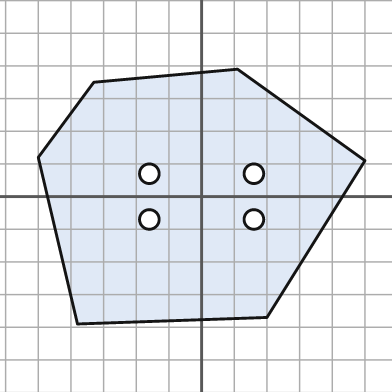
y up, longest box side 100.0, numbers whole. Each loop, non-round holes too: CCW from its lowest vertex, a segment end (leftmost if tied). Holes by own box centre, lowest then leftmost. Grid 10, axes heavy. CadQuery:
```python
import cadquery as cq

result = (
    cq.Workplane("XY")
    .moveTo(-38.0, -39.0)
    .lineTo(20.0, -37.0)
    .lineTo(50.0, 11.0)
    .lineTo(11.0, 39.0)
    .lineTo(-33.0, 35.0)
    .lineTo(-50.0, 12.0)
    .close()
    .moveTo(-16.0, -7.0)
    .circle(3.0)
    .moveTo(16.0, -7.0)
    .circle(3.0)
    .moveTo(-16.0, 7.0)
    .circle(3.0)
    .moveTo(16.0, 7.0)
    .circle(3.0)
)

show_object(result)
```